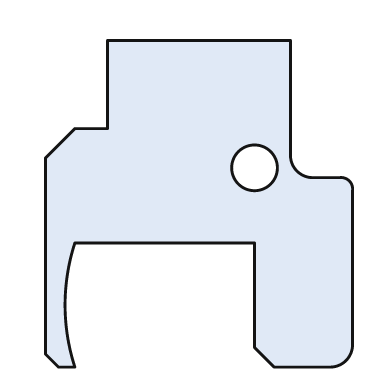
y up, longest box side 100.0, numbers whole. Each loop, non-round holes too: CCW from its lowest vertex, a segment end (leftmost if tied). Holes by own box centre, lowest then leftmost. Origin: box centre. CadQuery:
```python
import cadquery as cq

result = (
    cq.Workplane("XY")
    .moveTo(-43.0, -50.0)
    .lineTo(-38.0, -50.0)
    .threePointArc((-41.0, -31.0), (-38.0, -12.0))
    .lineTo(17.0, -12.0)
    .lineTo(17.0, -44.0)
    .lineTo(23.0, -50.0)
    .lineTo(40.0, -50.0)
    .threePointArc((45.0, -48.0), (47.0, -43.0))
    .lineTo(47.0, 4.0)
    .threePointArc((46.0, 7.0), (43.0, 8.0))
    .lineTo(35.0, 8.0)
    .threePointArc((30.0, 10.0), (28.0, 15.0))
    .lineTo(28.0, 50.0)
    .lineTo(-28.0, 50.0)
    .lineTo(-28.0, 23.0)
    .lineTo(-38.0, 23.0)
    .lineTo(-47.0, 14.0)
    .lineTo(-47.0, -46.0)
    .close()
    .moveTo(17.0, 11.0)
    .circle(7.0)
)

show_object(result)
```